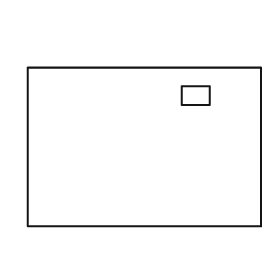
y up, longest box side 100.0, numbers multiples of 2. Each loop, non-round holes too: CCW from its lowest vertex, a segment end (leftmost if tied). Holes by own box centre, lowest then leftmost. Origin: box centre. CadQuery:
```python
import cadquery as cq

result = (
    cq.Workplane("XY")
    .moveTo(-50.0, -34.0)
    .lineTo(50.0, -34.0)
    .lineTo(50.0, 34.0)
    .lineTo(-50.0, 34.0)
    .close()
    .moveTo(16.0, 18.0)
    .lineTo(28.0, 18.0)
    .lineTo(28.0, 26.0)
    .lineTo(16.0, 26.0)
    .close()
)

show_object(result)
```